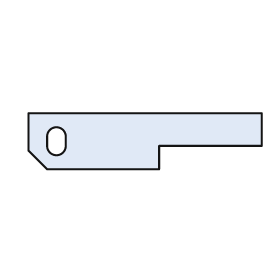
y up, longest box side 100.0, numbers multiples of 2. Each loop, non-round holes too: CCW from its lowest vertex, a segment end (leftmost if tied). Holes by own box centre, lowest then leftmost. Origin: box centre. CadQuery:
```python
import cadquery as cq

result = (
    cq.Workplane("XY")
    .moveTo(-42.0, -12.0)
    .lineTo(6.0, -12.0)
    .lineTo(6.0, -2.0)
    .lineTo(50.0, -2.0)
    .lineTo(50.0, 12.0)
    .lineTo(-50.0, 12.0)
    .lineTo(-50.0, -4.0)
    .close()
    .moveTo(-42.0, -2.0)
    .threePointArc((-38.0, -6.0), (-34.0, -2.0))
    .lineTo(-34.0, 2.0)
    .threePointArc((-38.0, 6.0), (-42.0, 2.0))
    .close()
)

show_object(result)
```